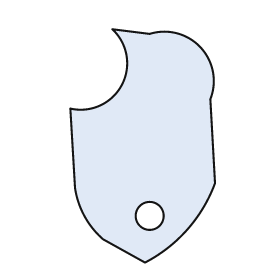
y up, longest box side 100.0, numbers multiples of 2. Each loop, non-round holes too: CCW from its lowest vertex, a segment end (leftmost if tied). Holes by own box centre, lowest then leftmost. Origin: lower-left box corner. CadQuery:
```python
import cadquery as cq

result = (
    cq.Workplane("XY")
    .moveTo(32.0, 0.0)
    .threePointArc((50.0, 14.0), (62.0, 34.0))
    .lineTo(60.0, 70.0)
    .threePointArc((56.0, 92.0), (34.0, 98.0))
    .lineTo(18.0, 100.0)
    .threePointArc((22.0, 76.0), (0.0, 66.0))
    .lineTo(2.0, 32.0)
    .threePointArc((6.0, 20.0), (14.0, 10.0))
    .close()
    .moveTo(34.0, 20.0)
    .circle(6.0)
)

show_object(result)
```